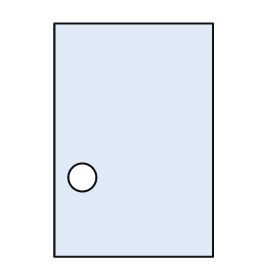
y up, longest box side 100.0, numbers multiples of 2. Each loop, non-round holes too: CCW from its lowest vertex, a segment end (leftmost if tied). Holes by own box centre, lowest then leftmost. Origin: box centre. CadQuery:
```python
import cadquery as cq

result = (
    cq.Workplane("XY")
    .moveTo(-34.0, -50.0)
    .lineTo(34.0, -50.0)
    .lineTo(34.0, 50.0)
    .lineTo(-34.0, 50.0)
    .close()
    .moveTo(-22.0, -16.0)
    .circle(6.0)
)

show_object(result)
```